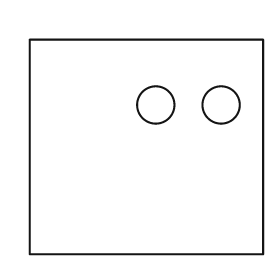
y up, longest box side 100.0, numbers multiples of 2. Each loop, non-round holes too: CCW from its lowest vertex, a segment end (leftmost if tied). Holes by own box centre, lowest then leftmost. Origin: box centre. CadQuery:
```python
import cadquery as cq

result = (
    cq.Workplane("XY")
    .moveTo(-50.0, -46.0)
    .lineTo(50.0, -46.0)
    .lineTo(50.0, 46.0)
    .lineTo(-50.0, 46.0)
    .close()
    .moveTo(4.0, 18.0)
    .circle(8.0)
    .moveTo(32.0, 18.0)
    .circle(8.0)
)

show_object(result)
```